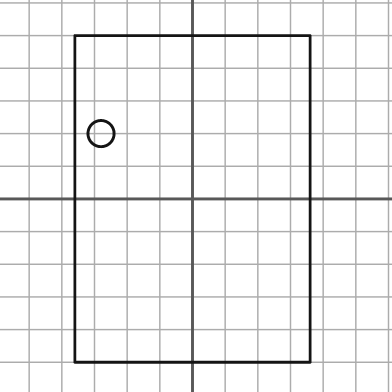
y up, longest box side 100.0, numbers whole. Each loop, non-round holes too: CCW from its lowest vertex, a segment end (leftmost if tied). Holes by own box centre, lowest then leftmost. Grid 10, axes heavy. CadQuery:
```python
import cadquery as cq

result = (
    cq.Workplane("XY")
    .moveTo(-36.0, -50.0)
    .lineTo(36.0, -50.0)
    .lineTo(36.0, 50.0)
    .lineTo(-36.0, 50.0)
    .close()
    .moveTo(-28.0, 20.0)
    .circle(4.0)
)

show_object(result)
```